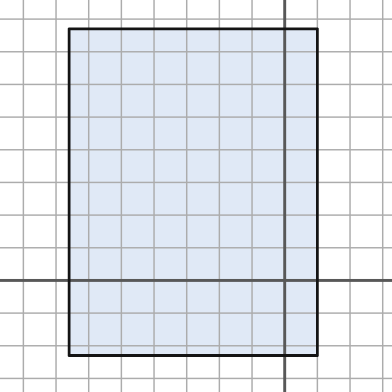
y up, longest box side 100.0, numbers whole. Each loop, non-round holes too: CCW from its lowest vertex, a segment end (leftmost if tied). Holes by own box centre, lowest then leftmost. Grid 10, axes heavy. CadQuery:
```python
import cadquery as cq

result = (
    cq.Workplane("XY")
    .moveTo(-66.0, -23.0)
    .lineTo(10.0, -23.0)
    .lineTo(10.0, 77.0)
    .lineTo(-66.0, 77.0)
    .close()
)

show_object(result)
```